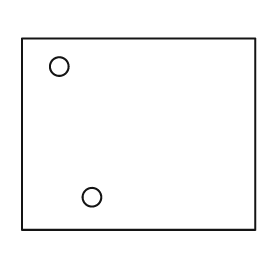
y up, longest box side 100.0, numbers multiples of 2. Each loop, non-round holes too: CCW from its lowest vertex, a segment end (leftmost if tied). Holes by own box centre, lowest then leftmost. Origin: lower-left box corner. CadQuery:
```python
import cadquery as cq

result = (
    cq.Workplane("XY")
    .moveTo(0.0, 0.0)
    .lineTo(100.0, 0.0)
    .lineTo(100.0, 82.0)
    .lineTo(0.0, 82.0)
    .close()
    .moveTo(30.0, 14.0)
    .circle(4.0)
    .moveTo(16.0, 70.0)
    .circle(4.0)
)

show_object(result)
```